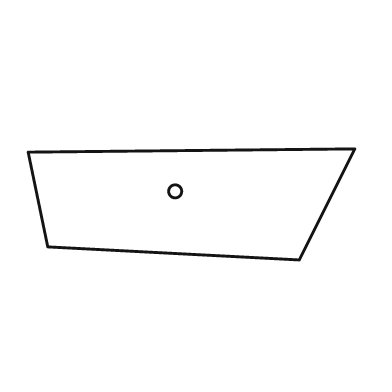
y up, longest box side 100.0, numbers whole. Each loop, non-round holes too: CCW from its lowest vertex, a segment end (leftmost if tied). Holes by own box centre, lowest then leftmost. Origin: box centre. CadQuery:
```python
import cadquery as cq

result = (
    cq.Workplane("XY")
    .moveTo(33.0, -17.0)
    .lineTo(50.0, 17.0)
    .lineTo(-50.0, 16.0)
    .lineTo(-44.0, -13.0)
    .close()
    .moveTo(-5.0, 4.0)
    .circle(2.0)
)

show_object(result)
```